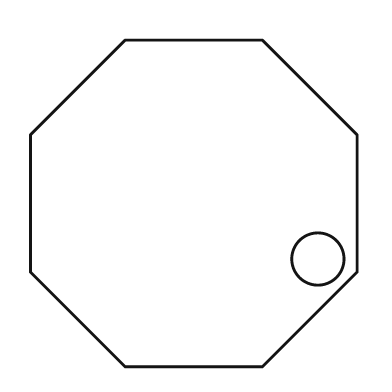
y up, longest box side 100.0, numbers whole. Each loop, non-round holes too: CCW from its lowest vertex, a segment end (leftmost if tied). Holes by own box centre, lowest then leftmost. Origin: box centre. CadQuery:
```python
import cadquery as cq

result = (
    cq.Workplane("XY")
    .moveTo(-21.0, -50.0)
    .lineTo(21.0, -50.0)
    .lineTo(50.0, -21.0)
    .lineTo(50.0, 21.0)
    .lineTo(21.0, 50.0)
    .lineTo(-21.0, 50.0)
    .lineTo(-50.0, 21.0)
    .lineTo(-50.0, -21.0)
    .close()
    .moveTo(38.0, -17.0)
    .circle(8.0)
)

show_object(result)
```